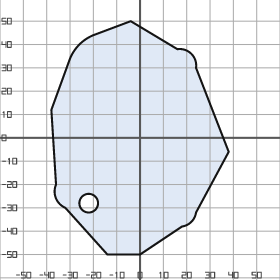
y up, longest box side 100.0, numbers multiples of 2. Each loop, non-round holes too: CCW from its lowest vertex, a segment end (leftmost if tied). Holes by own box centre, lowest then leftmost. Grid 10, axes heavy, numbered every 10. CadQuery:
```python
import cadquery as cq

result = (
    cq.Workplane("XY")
    .moveTo(-14.0, -50.0)
    .lineTo(0.0, -50.0)
    .lineTo(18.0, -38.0)
    .threePointArc((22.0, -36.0), (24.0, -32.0))
    .lineTo(38.0, -6.0)
    .lineTo(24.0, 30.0)
    .threePointArc((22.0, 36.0), (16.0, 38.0))
    .lineTo(-4.0, 50.0)
    .lineTo(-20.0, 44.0)
    .threePointArc((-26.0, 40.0), (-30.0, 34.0))
    .lineTo(-38.0, 12.0)
    .lineTo(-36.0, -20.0)
    .threePointArc((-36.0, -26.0), (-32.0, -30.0))
    .close()
    .moveTo(-22.0, -28.0)
    .circle(4.0)
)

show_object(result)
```